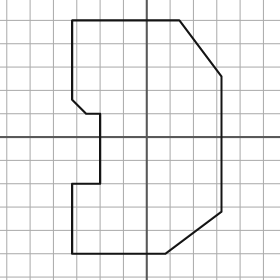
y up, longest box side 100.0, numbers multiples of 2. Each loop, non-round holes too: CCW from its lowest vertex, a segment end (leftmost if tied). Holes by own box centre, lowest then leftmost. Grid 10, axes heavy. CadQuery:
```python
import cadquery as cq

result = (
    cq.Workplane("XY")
    .moveTo(-32.0, -50.0)
    .lineTo(8.0, -50.0)
    .lineTo(32.0, -32.0)
    .lineTo(32.0, 26.0)
    .lineTo(14.0, 50.0)
    .lineTo(-32.0, 50.0)
    .lineTo(-32.0, 16.0)
    .lineTo(-26.0, 10.0)
    .lineTo(-20.0, 10.0)
    .lineTo(-20.0, -20.0)
    .lineTo(-32.0, -20.0)
    .close()
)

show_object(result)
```